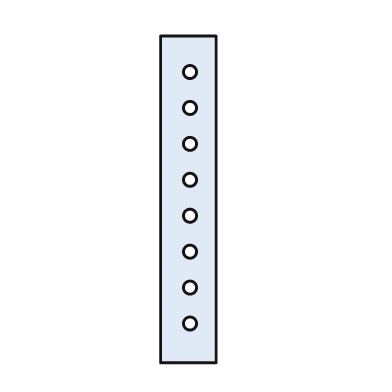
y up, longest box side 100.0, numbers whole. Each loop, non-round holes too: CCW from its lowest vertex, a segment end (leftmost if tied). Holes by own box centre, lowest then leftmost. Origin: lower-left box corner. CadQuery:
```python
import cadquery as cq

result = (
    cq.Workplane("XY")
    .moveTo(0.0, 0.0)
    .lineTo(17.0, 0.0)
    .lineTo(17.0, 100.0)
    .lineTo(0.0, 100.0)
    .close()
    .moveTo(9.0, 12.0)
    .circle(2.0)
    .moveTo(9.0, 23.0)
    .circle(2.0)
    .moveTo(9.0, 34.0)
    .circle(2.0)
    .moveTo(9.0, 45.0)
    .circle(2.0)
    .moveTo(9.0, 56.0)
    .circle(2.0)
    .moveTo(9.0, 67.0)
    .circle(2.0)
    .moveTo(9.0, 78.0)
    .circle(2.0)
    .moveTo(9.0, 89.0)
    .circle(2.0)
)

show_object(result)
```